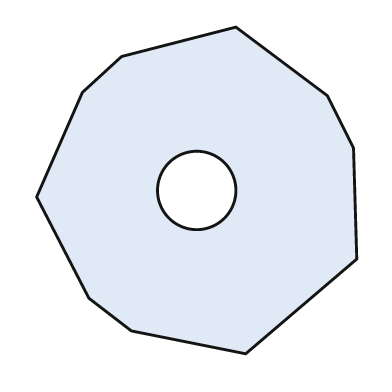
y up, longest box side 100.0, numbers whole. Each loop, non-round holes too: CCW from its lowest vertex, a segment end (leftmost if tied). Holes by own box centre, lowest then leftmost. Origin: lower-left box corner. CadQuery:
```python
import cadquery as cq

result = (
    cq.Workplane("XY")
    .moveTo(64.0, 0.0)
    .lineTo(98.0, 29.0)
    .lineTo(97.0, 63.0)
    .lineTo(89.0, 79.0)
    .lineTo(61.0, 100.0)
    .lineTo(26.0, 91.0)
    .lineTo(14.0, 80.0)
    .lineTo(0.0, 48.0)
    .lineTo(16.0, 17.0)
    .lineTo(29.0, 7.0)
    .close()
    .moveTo(49.0, 50.0)
    .circle(12.0)
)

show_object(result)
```